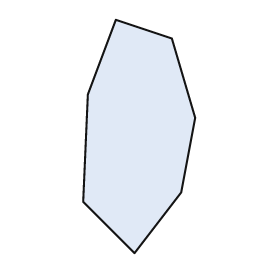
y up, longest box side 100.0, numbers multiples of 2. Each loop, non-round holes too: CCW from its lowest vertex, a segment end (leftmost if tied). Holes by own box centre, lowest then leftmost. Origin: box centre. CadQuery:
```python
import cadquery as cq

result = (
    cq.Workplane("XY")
    .moveTo(-2.0, -50.0)
    .lineTo(18.0, -24.0)
    .lineTo(24.0, 8.0)
    .lineTo(14.0, 42.0)
    .lineTo(-10.0, 50.0)
    .lineTo(-22.0, 18.0)
    .lineTo(-24.0, -28.0)
    .close()
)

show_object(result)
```